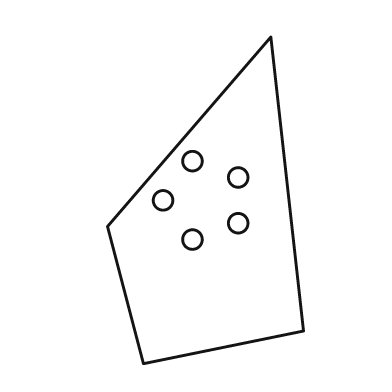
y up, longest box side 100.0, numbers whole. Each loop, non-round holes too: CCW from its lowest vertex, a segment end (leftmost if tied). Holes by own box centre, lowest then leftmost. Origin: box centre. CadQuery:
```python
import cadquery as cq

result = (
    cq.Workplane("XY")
    .moveTo(-19.0, -50.0)
    .lineTo(30.0, -40.0)
    .lineTo(20.0, 50.0)
    .lineTo(-30.0, -8.0)
    .close()
    .moveTo(-4.0, -12.0)
    .circle(3.0)
    .moveTo(10.0, -7.0)
    .circle(3.0)
    .moveTo(-13.0, 0.0)
    .circle(3.0)
    .moveTo(10.0, 7.0)
    .circle(3.0)
    .moveTo(-4.0, 12.0)
    .circle(3.0)
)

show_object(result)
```